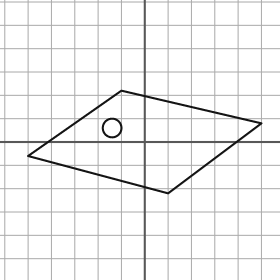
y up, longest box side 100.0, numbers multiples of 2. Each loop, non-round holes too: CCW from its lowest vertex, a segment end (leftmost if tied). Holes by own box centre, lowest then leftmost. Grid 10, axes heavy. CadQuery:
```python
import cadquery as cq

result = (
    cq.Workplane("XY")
    .moveTo(10.0, -22.0)
    .lineTo(50.0, 8.0)
    .lineTo(-10.0, 22.0)
    .lineTo(-50.0, -6.0)
    .close()
    .moveTo(-14.0, 6.0)
    .circle(4.0)
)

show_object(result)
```